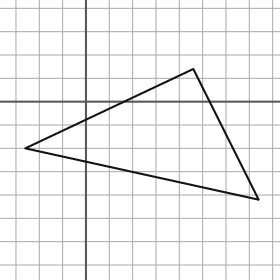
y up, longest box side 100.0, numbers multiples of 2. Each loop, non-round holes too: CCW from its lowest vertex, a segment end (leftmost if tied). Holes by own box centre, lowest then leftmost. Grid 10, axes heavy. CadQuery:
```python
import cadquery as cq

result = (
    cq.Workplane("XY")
    .moveTo(74.0, -42.0)
    .lineTo(46.0, 14.0)
    .lineTo(-26.0, -20.0)
    .close()
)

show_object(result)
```